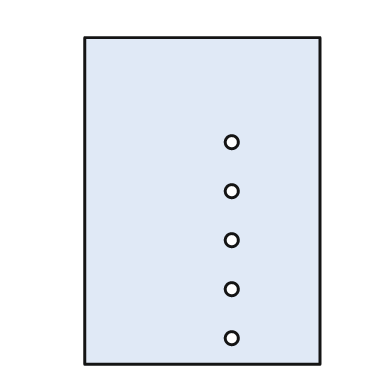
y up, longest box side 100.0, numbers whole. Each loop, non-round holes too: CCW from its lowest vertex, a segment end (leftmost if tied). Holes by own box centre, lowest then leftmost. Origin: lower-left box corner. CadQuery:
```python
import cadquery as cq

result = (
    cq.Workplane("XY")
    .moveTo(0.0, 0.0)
    .lineTo(72.0, 0.0)
    .lineTo(72.0, 100.0)
    .lineTo(0.0, 100.0)
    .close()
    .moveTo(45.0, 8.0)
    .circle(2.0)
    .moveTo(45.0, 23.0)
    .circle(2.0)
    .moveTo(45.0, 38.0)
    .circle(2.0)
    .moveTo(45.0, 53.0)
    .circle(2.0)
    .moveTo(45.0, 68.0)
    .circle(2.0)
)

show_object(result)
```